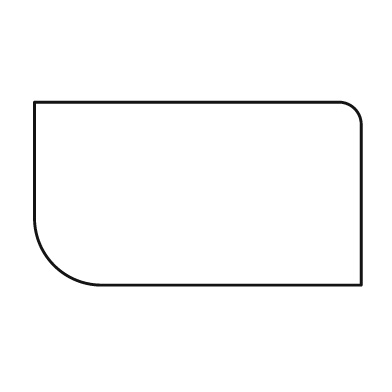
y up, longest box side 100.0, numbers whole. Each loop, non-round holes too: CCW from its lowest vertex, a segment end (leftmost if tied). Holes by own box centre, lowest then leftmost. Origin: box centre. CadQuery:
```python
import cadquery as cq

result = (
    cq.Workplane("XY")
    .moveTo(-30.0, -28.0)
    .lineTo(50.0, -28.0)
    .lineTo(50.0, 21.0)
    .threePointArc((48.0, 26.0), (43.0, 28.0))
    .lineTo(-50.0, 28.0)
    .lineTo(-50.0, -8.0)
    .threePointArc((-44.0, -22.0), (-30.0, -28.0))
    .close()
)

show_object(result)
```